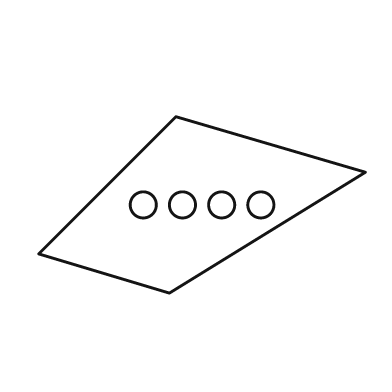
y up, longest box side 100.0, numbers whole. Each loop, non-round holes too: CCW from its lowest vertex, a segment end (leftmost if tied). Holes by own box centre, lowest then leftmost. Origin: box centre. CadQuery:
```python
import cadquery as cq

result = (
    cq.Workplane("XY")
    .moveTo(-10.0, -27.0)
    .lineTo(50.0, 10.0)
    .lineTo(-8.0, 27.0)
    .lineTo(-50.0, -15.0)
    .close()
    .moveTo(-18.0, 0.0)
    .circle(4.0)
    .moveTo(-6.0, 0.0)
    .circle(4.0)
    .moveTo(6.0, 0.0)
    .circle(4.0)
    .moveTo(18.0, 0.0)
    .circle(4.0)
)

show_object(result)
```